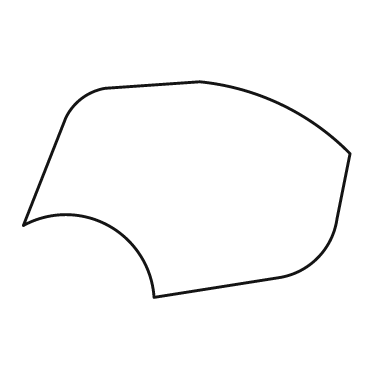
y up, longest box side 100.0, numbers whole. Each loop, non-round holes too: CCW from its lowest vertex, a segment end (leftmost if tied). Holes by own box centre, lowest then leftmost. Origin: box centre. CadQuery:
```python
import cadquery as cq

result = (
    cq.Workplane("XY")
    .moveTo(-10.0, -33.0)
    .lineTo(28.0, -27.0)
    .threePointArc((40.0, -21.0), (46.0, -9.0))
    .lineTo(50.0, 11.0)
    .threePointArc((29.0, 26.0), (4.0, 33.0))
    .lineTo(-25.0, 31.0)
    .threePointArc((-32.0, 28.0), (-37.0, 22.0))
    .lineTo(-50.0, -11.0)
    .threePointArc((-24.0, -11.0), (-10.0, -33.0))
    .close()
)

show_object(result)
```